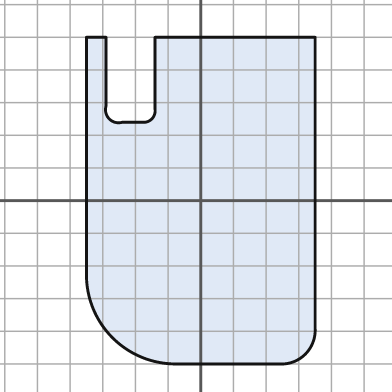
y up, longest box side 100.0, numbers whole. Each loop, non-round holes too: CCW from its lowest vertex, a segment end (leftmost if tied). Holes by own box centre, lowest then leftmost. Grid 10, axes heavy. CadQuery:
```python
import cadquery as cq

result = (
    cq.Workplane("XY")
    .moveTo(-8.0, -50.0)
    .lineTo(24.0, -50.0)
    .threePointArc((32.0, -47.0), (35.0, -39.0))
    .lineTo(35.0, 50.0)
    .lineTo(-14.0, 50.0)
    .lineTo(-14.0, 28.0)
    .threePointArc((-15.0, 25.0), (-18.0, 24.0))
    .lineTo(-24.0, 24.0)
    .threePointArc((-28.0, 25.0), (-29.0, 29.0))
    .lineTo(-29.0, 50.0)
    .lineTo(-35.0, 50.0)
    .lineTo(-35.0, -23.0)
    .threePointArc((-27.0, -42.0), (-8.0, -50.0))
    .close()
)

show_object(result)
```